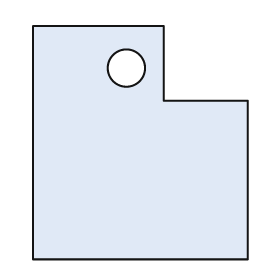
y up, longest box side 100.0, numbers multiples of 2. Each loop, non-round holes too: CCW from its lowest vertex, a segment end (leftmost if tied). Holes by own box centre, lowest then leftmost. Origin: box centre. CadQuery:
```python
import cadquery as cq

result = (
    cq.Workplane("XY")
    .moveTo(-46.0, -50.0)
    .lineTo(46.0, -50.0)
    .lineTo(46.0, 18.0)
    .lineTo(10.0, 18.0)
    .lineTo(10.0, 50.0)
    .lineTo(-46.0, 50.0)
    .close()
    .moveTo(-6.0, 32.0)
    .circle(8.0)
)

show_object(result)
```